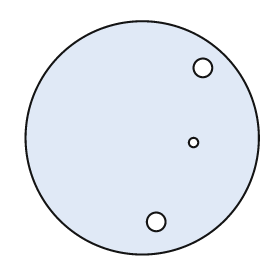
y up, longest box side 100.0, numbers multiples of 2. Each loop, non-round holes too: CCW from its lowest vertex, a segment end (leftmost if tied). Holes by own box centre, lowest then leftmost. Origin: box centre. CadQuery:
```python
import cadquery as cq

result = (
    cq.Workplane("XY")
    .moveTo(0.0, 0.0)
    .circle(50.0)
    .moveTo(6.0, -36.0)
    .circle(4.0)
    .moveTo(22.0, -2.0)
    .circle(2.0)
    .moveTo(26.0, 30.0)
    .circle(4.0)
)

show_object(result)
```